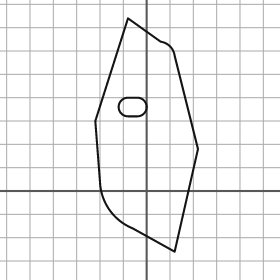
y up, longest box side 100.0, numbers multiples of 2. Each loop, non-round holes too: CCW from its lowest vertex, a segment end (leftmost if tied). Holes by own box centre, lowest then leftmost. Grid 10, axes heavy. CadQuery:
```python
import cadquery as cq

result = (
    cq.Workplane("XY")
    .moveTo(12.0, -26.0)
    .lineTo(22.0, 18.0)
    .lineTo(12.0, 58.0)
    .threePointArc((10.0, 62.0), (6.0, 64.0))
    .lineTo(-8.0, 74.0)
    .lineTo(-22.0, 30.0)
    .lineTo(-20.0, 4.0)
    .threePointArc((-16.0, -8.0), (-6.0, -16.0))
    .close()
    .moveTo(-8.0, 32.0)
    .lineTo(-4.0, 32.0)
    .threePointArc((0.0, 36.0), (-4.0, 40.0))
    .lineTo(-8.0, 40.0)
    .threePointArc((-12.0, 36.0), (-8.0, 32.0))
    .close()
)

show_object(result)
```